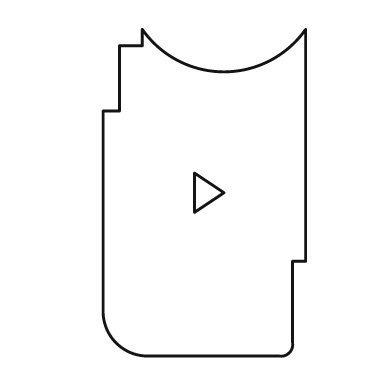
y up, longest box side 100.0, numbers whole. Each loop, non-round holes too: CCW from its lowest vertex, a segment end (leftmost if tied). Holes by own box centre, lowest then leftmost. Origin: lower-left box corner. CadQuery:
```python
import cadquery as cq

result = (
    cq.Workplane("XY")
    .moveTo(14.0, 0.0)
    .lineTo(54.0, 0.0)
    .threePointArc((57.0, 1.0), (58.0, 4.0))
    .lineTo(58.0, 29.0)
    .lineTo(62.0, 29.0)
    .lineTo(62.0, 100.0)
    .threePointArc((37.0, 87.0), (12.0, 100.0))
    .lineTo(12.0, 95.0)
    .lineTo(5.0, 95.0)
    .lineTo(5.0, 75.0)
    .lineTo(0.0, 75.0)
    .lineTo(0.0, 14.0)
    .threePointArc((4.0, 4.0), (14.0, 0.0))
    .close()
    .moveTo(28.0, 44.0)
    .lineTo(37.0, 50.0)
    .lineTo(28.0, 56.0)
    .close()
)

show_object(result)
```